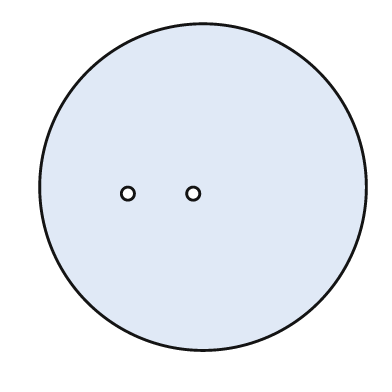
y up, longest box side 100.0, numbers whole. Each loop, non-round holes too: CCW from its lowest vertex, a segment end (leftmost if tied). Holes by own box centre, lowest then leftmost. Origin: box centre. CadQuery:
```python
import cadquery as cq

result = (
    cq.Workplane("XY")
    .moveTo(0.0, 0.0)
    .circle(50.0)
    .moveTo(-23.0, -2.0)
    .circle(2.0)
    .moveTo(-3.0, -2.0)
    .circle(2.0)
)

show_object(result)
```